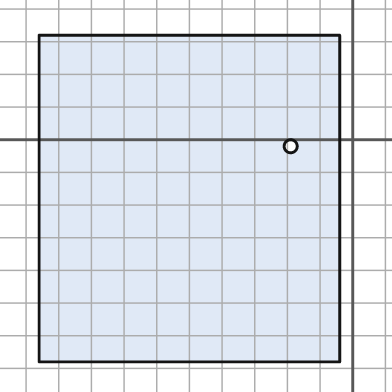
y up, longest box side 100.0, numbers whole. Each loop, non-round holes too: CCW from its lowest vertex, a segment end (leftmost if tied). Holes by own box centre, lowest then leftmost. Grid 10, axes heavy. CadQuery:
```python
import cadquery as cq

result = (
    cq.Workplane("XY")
    .moveTo(-96.0, -68.0)
    .lineTo(-4.0, -68.0)
    .lineTo(-4.0, 32.0)
    .lineTo(-96.0, 32.0)
    .close()
    .moveTo(-19.0, -2.0)
    .circle(2.0)
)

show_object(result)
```